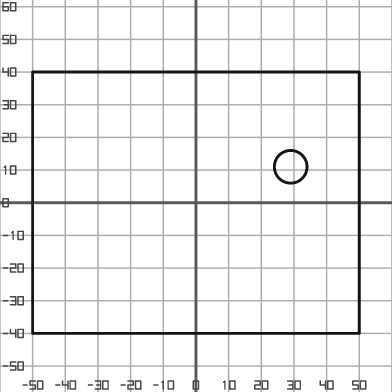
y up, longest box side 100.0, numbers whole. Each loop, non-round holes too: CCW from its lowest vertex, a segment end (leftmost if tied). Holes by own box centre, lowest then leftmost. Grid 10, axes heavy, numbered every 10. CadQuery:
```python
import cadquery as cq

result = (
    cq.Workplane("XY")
    .moveTo(-50.0, -40.0)
    .lineTo(50.0, -40.0)
    .lineTo(50.0, 40.0)
    .lineTo(-50.0, 40.0)
    .close()
    .moveTo(29.0, 11.0)
    .circle(5.0)
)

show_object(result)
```